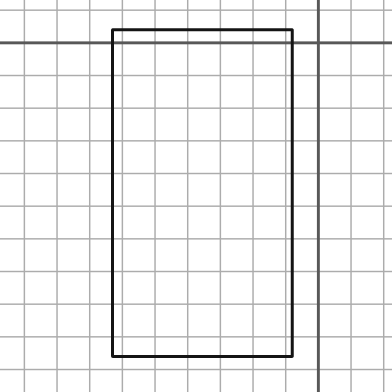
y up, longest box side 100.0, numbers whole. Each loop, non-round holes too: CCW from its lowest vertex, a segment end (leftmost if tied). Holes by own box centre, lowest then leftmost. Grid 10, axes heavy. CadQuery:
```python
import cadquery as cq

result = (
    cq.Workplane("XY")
    .moveTo(-63.0, -96.0)
    .lineTo(-8.0, -96.0)
    .lineTo(-8.0, 4.0)
    .lineTo(-63.0, 4.0)
    .close()
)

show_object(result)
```